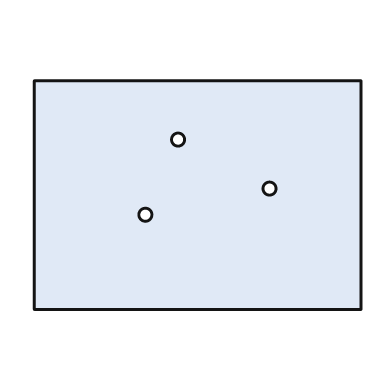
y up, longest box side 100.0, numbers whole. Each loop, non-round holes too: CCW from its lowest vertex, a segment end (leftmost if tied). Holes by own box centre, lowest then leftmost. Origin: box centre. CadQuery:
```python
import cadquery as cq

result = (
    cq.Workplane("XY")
    .moveTo(-50.0, -35.0)
    .lineTo(50.0, -35.0)
    .lineTo(50.0, 35.0)
    .lineTo(-50.0, 35.0)
    .close()
    .moveTo(-16.0, -6.0)
    .circle(2.0)
    .moveTo(22.0, 2.0)
    .circle(2.0)
    .moveTo(-6.0, 17.0)
    .circle(2.0)
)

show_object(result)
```